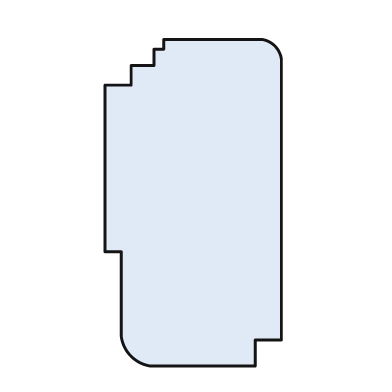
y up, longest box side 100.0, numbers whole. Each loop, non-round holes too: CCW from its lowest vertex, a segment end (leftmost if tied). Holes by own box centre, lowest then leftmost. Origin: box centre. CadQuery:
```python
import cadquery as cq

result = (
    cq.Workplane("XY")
    .moveTo(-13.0, -50.0)
    .lineTo(19.0, -50.0)
    .lineTo(19.0, -42.0)
    .lineTo(27.0, -42.0)
    .lineTo(27.0, 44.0)
    .threePointArc((25.0, 48.0), (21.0, 50.0))
    .lineTo(-9.0, 50.0)
    .lineTo(-9.0, 47.0)
    .lineTo(-12.0, 47.0)
    .lineTo(-12.0, 42.0)
    .lineTo(-19.0, 42.0)
    .lineTo(-19.0, 36.0)
    .lineTo(-27.0, 36.0)
    .lineTo(-27.0, -15.0)
    .lineTo(-22.0, -15.0)
    .lineTo(-22.0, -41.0)
    .threePointArc((-19.0, -47.0), (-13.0, -50.0))
    .close()
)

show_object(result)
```